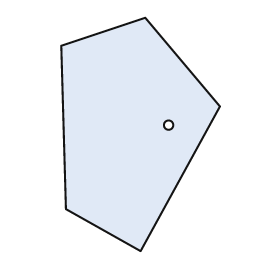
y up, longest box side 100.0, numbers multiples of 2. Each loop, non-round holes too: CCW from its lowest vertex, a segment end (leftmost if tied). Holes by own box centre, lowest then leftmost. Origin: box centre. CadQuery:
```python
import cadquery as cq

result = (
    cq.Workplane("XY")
    .moveTo(0.0, -50.0)
    .lineTo(34.0, 12.0)
    .lineTo(2.0, 50.0)
    .lineTo(-34.0, 38.0)
    .lineTo(-32.0, -32.0)
    .close()
    .moveTo(12.0, 4.0)
    .circle(2.0)
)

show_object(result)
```